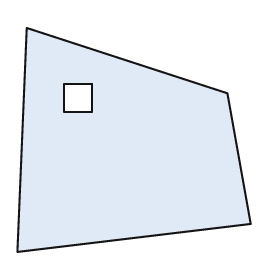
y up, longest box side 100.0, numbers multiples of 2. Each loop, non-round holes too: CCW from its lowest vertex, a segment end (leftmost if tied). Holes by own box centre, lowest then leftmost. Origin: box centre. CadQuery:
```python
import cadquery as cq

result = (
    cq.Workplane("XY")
    .moveTo(-50.0, -48.0)
    .lineTo(50.0, -36.0)
    .lineTo(40.0, 20.0)
    .lineTo(-46.0, 48.0)
    .close()
    .moveTo(-30.0, 12.0)
    .lineTo(-18.0, 12.0)
    .lineTo(-18.0, 24.0)
    .lineTo(-30.0, 24.0)
    .close()
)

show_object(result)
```